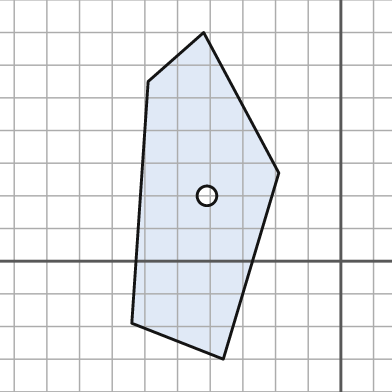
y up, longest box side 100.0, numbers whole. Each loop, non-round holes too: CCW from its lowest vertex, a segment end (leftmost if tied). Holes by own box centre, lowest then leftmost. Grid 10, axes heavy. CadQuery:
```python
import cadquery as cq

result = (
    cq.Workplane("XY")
    .moveTo(-36.0, -30.0)
    .lineTo(-19.0, 27.0)
    .lineTo(-42.0, 70.0)
    .lineTo(-59.0, 55.0)
    .lineTo(-64.0, -19.0)
    .close()
    .moveTo(-41.0, 20.0)
    .circle(3.0)
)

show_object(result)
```